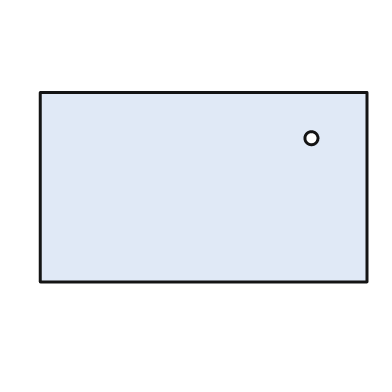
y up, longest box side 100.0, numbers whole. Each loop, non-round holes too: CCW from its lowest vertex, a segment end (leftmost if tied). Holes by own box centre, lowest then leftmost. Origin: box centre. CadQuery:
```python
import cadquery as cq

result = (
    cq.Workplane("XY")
    .moveTo(-50.0, -29.0)
    .lineTo(50.0, -29.0)
    .lineTo(50.0, 29.0)
    .lineTo(-50.0, 29.0)
    .close()
    .moveTo(33.0, 15.0)
    .circle(2.0)
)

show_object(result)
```